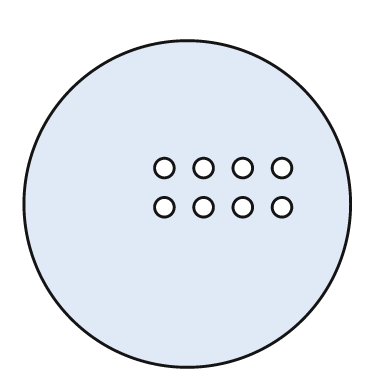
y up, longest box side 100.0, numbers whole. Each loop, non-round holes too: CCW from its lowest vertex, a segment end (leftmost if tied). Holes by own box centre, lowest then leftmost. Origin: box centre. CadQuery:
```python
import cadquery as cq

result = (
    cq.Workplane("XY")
    .moveTo(0.0, 0.0)
    .circle(50.0)
    .moveTo(-7.0, -1.0)
    .circle(3.0)
    .moveTo(5.0, -1.0)
    .circle(3.0)
    .moveTo(17.0, -1.0)
    .circle(3.0)
    .moveTo(29.0, -1.0)
    .circle(3.0)
    .moveTo(-7.0, 11.0)
    .circle(3.0)
    .moveTo(5.0, 11.0)
    .circle(3.0)
    .moveTo(17.0, 11.0)
    .circle(3.0)
    .moveTo(29.0, 11.0)
    .circle(3.0)
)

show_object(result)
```